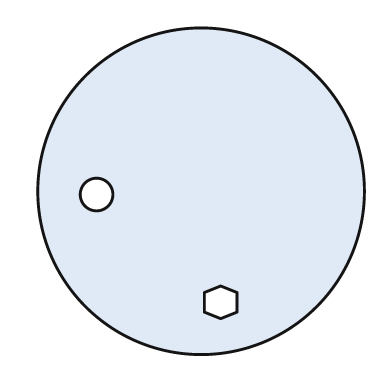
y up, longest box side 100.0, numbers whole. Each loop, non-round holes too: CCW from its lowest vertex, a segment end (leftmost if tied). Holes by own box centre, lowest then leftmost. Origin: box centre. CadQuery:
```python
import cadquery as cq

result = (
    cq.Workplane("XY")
    .moveTo(0.0, 0.0)
    .circle(50.0)
    .moveTo(6.0, -39.0)
    .lineTo(11.0, -37.0)
    .lineTo(11.0, -31.0)
    .lineTo(6.0, -29.0)
    .lineTo(1.0, -31.0)
    .lineTo(1.0, -37.0)
    .close()
    .moveTo(-32.0, -1.0)
    .circle(5.0)
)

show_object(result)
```